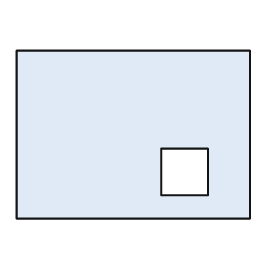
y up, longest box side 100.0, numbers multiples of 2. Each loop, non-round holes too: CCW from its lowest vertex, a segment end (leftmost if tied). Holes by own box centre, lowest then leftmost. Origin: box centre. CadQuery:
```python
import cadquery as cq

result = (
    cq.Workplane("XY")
    .moveTo(-50.0, -36.0)
    .lineTo(50.0, -36.0)
    .lineTo(50.0, 36.0)
    .lineTo(-50.0, 36.0)
    .close()
    .moveTo(12.0, -26.0)
    .lineTo(32.0, -26.0)
    .lineTo(32.0, -6.0)
    .lineTo(12.0, -6.0)
    .close()
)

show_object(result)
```